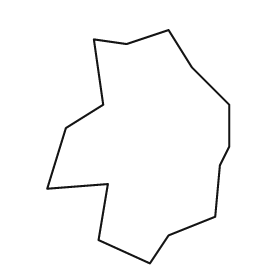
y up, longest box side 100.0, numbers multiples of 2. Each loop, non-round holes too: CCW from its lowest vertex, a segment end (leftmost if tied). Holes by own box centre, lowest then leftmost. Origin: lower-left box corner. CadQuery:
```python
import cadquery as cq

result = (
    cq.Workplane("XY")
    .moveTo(44.0, 0.0)
    .lineTo(52.0, 12.0)
    .lineTo(72.0, 20.0)
    .lineTo(74.0, 42.0)
    .lineTo(78.0, 50.0)
    .lineTo(78.0, 68.0)
    .lineTo(62.0, 84.0)
    .lineTo(52.0, 100.0)
    .lineTo(34.0, 94.0)
    .lineTo(20.0, 96.0)
    .lineTo(24.0, 68.0)
    .lineTo(8.0, 58.0)
    .lineTo(0.0, 32.0)
    .lineTo(26.0, 34.0)
    .lineTo(22.0, 10.0)
    .close()
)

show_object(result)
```